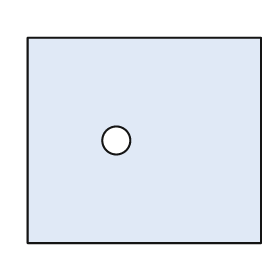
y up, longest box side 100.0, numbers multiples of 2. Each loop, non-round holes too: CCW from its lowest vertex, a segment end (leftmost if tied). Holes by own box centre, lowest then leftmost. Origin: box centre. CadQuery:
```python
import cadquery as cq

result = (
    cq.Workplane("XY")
    .moveTo(-50.0, -44.0)
    .lineTo(50.0, -44.0)
    .lineTo(50.0, 44.0)
    .lineTo(-50.0, 44.0)
    .close()
    .moveTo(-12.0, 0.0)
    .circle(6.0)
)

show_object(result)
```